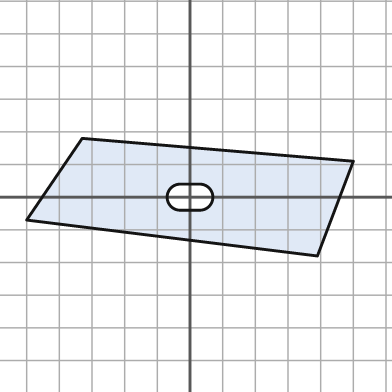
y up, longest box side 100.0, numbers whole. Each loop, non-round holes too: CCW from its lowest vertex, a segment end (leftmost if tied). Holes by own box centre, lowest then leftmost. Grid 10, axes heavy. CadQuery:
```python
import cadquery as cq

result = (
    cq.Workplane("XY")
    .moveTo(39.0, -18.0)
    .lineTo(50.0, 11.0)
    .lineTo(-33.0, 18.0)
    .lineTo(-50.0, -7.0)
    .close()
    .moveTo(-3.0, -4.0)
    .lineTo(3.0, -4.0)
    .threePointArc((7.0, 0.0), (3.0, 4.0))
    .lineTo(-3.0, 4.0)
    .threePointArc((-7.0, 0.0), (-3.0, -4.0))
    .close()
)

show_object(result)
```